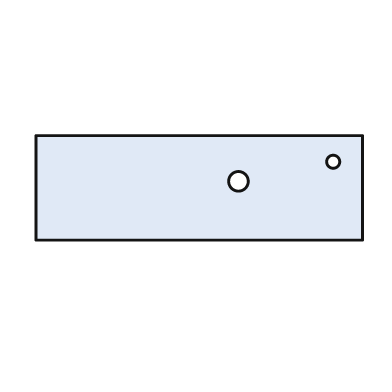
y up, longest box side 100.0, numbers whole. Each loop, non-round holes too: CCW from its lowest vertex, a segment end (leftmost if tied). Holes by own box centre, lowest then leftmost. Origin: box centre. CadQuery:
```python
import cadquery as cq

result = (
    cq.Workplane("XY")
    .moveTo(-50.0, -16.0)
    .lineTo(50.0, -16.0)
    .lineTo(50.0, 16.0)
    .lineTo(-50.0, 16.0)
    .close()
    .moveTo(12.0, 2.0)
    .circle(3.0)
    .moveTo(41.0, 8.0)
    .circle(2.0)
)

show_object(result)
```